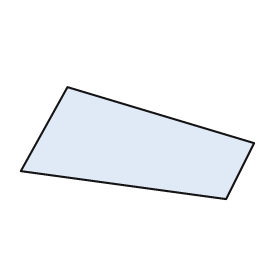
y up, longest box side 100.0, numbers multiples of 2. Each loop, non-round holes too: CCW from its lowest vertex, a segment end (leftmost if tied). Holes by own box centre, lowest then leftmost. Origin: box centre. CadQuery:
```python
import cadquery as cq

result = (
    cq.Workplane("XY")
    .moveTo(38.0, -24.0)
    .lineTo(50.0, 0.0)
    .lineTo(-30.0, 24.0)
    .lineTo(-50.0, -12.0)
    .close()
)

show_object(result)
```